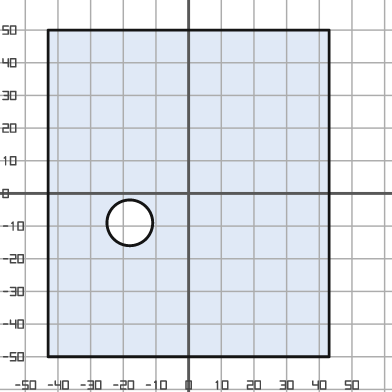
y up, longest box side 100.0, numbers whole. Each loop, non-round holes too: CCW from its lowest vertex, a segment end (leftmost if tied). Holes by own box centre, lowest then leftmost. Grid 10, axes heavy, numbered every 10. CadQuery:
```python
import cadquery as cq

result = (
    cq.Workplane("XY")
    .moveTo(-43.0, -50.0)
    .lineTo(43.0, -50.0)
    .lineTo(43.0, 50.0)
    .lineTo(-43.0, 50.0)
    .close()
    .moveTo(-18.0, -9.0)
    .circle(7.0)
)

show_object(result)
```